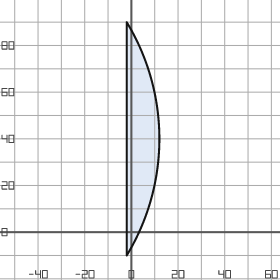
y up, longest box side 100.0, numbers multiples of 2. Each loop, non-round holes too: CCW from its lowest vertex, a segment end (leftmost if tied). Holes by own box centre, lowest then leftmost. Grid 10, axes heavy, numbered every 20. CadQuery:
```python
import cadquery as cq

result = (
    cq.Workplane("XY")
    .moveTo(-2.0, -10.0)
    .threePointArc((12.0, 40.0), (-2.0, 90.0))
    .close()
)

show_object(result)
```